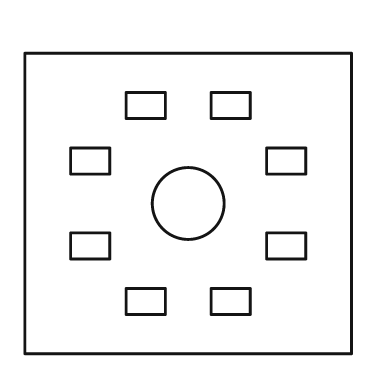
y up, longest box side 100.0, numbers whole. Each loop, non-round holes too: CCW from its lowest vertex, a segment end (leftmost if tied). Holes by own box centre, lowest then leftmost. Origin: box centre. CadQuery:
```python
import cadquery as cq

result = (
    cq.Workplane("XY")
    .moveTo(-50.0, -46.0)
    .lineTo(50.0, -46.0)
    .lineTo(50.0, 46.0)
    .lineTo(-50.0, 46.0)
    .close()
    .moveTo(-19.0, -34.0)
    .lineTo(-7.0, -34.0)
    .lineTo(-7.0, -26.0)
    .lineTo(-19.0, -26.0)
    .close()
    .moveTo(7.0, -34.0)
    .lineTo(19.0, -34.0)
    .lineTo(19.0, -26.0)
    .lineTo(7.0, -26.0)
    .close()
    .moveTo(-36.0, -17.0)
    .lineTo(-24.0, -17.0)
    .lineTo(-24.0, -9.0)
    .lineTo(-36.0, -9.0)
    .close()
    .moveTo(24.0, -17.0)
    .lineTo(36.0, -17.0)
    .lineTo(36.0, -9.0)
    .lineTo(24.0, -9.0)
    .close()
    .moveTo(0.0, 0.0)
    .circle(11.0)
    .moveTo(-36.0, 9.0)
    .lineTo(-24.0, 9.0)
    .lineTo(-24.0, 17.0)
    .lineTo(-36.0, 17.0)
    .close()
    .moveTo(24.0, 9.0)
    .lineTo(36.0, 9.0)
    .lineTo(36.0, 17.0)
    .lineTo(24.0, 17.0)
    .close()
    .moveTo(-19.0, 26.0)
    .lineTo(-7.0, 26.0)
    .lineTo(-7.0, 34.0)
    .lineTo(-19.0, 34.0)
    .close()
    .moveTo(7.0, 26.0)
    .lineTo(19.0, 26.0)
    .lineTo(19.0, 34.0)
    .lineTo(7.0, 34.0)
    .close()
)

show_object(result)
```